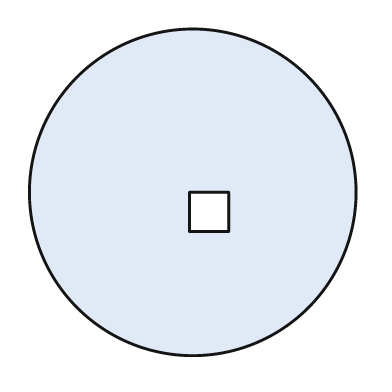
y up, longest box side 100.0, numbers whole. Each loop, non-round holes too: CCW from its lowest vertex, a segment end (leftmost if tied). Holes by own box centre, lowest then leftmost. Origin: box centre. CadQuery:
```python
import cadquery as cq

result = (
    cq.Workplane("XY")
    .moveTo(0.0, 0.0)
    .circle(50.0)
    .moveTo(-1.0, -12.0)
    .lineTo(11.0, -12.0)
    .lineTo(11.0, 0.0)
    .lineTo(-1.0, 0.0)
    .close()
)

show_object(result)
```